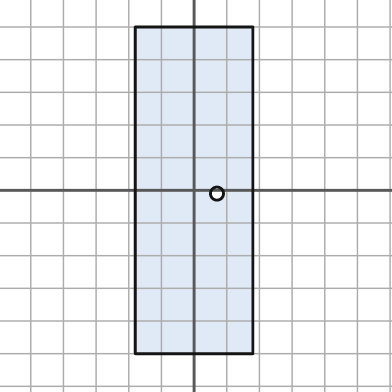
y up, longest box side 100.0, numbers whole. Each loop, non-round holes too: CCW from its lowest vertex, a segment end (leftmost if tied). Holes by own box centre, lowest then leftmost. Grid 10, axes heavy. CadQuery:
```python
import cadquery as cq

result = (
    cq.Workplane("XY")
    .moveTo(-18.0, -50.0)
    .lineTo(18.0, -50.0)
    .lineTo(18.0, 50.0)
    .lineTo(-18.0, 50.0)
    .close()
    .moveTo(7.0, -1.0)
    .circle(2.0)
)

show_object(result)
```